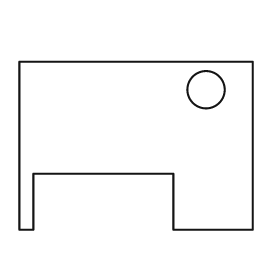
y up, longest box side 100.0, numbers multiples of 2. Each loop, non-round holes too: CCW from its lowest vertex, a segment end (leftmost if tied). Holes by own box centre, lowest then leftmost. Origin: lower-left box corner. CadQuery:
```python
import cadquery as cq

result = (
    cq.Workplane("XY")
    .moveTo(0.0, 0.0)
    .lineTo(6.0, 0.0)
    .lineTo(6.0, 24.0)
    .lineTo(66.0, 24.0)
    .lineTo(66.0, 0.0)
    .lineTo(100.0, 0.0)
    .lineTo(100.0, 72.0)
    .lineTo(0.0, 72.0)
    .close()
    .moveTo(80.0, 60.0)
    .circle(8.0)
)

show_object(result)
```